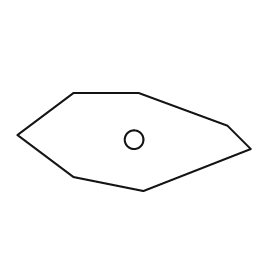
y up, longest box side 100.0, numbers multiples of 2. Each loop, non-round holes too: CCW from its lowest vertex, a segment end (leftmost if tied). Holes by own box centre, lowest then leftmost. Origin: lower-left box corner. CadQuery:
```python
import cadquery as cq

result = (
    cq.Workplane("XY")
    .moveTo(54.0, 0.0)
    .lineTo(100.0, 18.0)
    .lineTo(90.0, 28.0)
    .lineTo(52.0, 42.0)
    .lineTo(24.0, 42.0)
    .lineTo(0.0, 24.0)
    .lineTo(24.0, 6.0)
    .close()
    .moveTo(50.0, 22.0)
    .circle(4.0)
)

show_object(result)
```